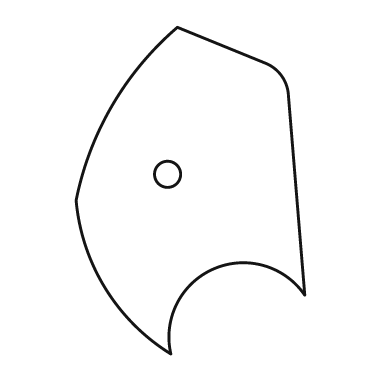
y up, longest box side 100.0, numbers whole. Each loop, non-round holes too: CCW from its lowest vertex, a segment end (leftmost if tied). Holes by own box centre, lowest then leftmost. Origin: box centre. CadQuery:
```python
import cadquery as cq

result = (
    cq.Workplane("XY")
    .moveTo(-6.0, -50.0)
    .threePointArc((7.0, -24.0), (35.0, -32.0))
    .lineTo(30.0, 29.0)
    .threePointArc((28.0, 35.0), (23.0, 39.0))
    .lineTo(-4.0, 50.0)
    .threePointArc((-24.0, 26.0), (-35.0, -3.0))
    .threePointArc((-26.0, -30.0), (-6.0, -50.0))
    .close()
    .moveTo(-7.0, 5.0)
    .circle(4.0)
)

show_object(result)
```